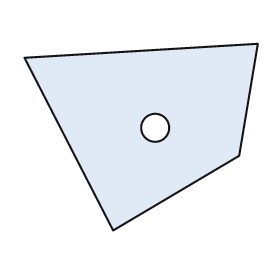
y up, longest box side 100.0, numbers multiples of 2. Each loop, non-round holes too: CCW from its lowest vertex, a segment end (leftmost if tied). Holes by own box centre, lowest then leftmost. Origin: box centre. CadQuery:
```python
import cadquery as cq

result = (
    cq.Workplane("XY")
    .moveTo(-12.0, -40.0)
    .lineTo(42.0, -8.0)
    .lineTo(50.0, 40.0)
    .lineTo(-50.0, 34.0)
    .close()
    .moveTo(6.0, 4.0)
    .circle(6.0)
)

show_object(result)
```